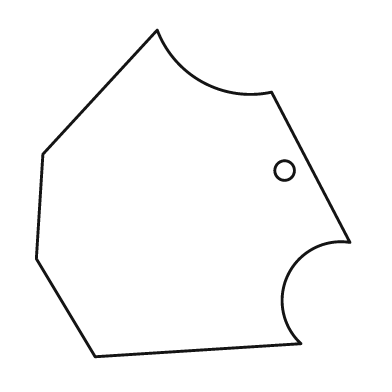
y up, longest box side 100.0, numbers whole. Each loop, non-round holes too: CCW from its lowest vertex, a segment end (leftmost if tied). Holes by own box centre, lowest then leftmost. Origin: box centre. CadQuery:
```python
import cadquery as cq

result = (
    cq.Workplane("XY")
    .moveTo(-30.0, -50.0)
    .lineTo(33.0, -46.0)
    .threePointArc((29.0, -25.0), (48.0, -15.0))
    .lineTo(24.0, 31.0)
    .threePointArc((3.0, 34.0), (-11.0, 50.0))
    .lineTo(-46.0, 12.0)
    .lineTo(-48.0, -20.0)
    .close()
    .moveTo(28.0, 7.0)
    .circle(3.0)
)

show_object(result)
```